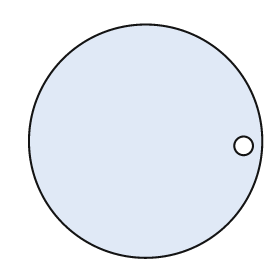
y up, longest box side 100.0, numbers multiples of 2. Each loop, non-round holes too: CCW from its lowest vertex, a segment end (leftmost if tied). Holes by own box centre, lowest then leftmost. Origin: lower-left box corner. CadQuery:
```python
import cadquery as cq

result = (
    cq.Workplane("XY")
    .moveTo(50.0, 50.0)
    .circle(50.0)
    .moveTo(92.0, 48.0)
    .circle(4.0)
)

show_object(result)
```